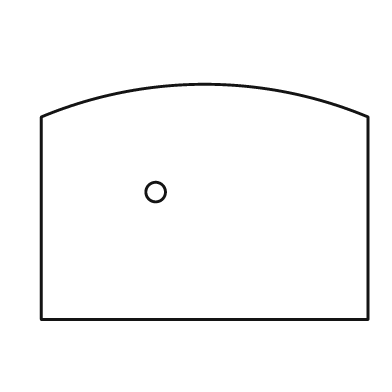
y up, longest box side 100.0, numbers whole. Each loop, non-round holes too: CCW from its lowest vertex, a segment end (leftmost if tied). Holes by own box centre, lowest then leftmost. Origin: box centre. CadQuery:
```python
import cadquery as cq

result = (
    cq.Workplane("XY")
    .moveTo(-50.0, -36.0)
    .lineTo(50.0, -36.0)
    .lineTo(50.0, 26.0)
    .threePointArc((0.0, 36.0), (-50.0, 26.0))
    .close()
    .moveTo(-15.0, 3.0)
    .circle(3.0)
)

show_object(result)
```